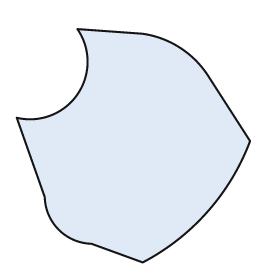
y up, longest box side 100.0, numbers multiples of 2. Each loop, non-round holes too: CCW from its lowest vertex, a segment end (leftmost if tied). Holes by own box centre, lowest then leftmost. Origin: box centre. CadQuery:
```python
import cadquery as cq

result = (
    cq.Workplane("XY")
    .moveTo(4.0, -50.0)
    .threePointArc((32.0, -28.0), (50.0, 2.0))
    .lineTo(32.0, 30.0)
    .threePointArc((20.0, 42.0), (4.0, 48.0))
    .lineTo(-24.0, 50.0)
    .threePointArc((-24.0, 22.0), (-50.0, 12.0))
    .lineTo(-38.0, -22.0)
    .threePointArc((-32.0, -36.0), (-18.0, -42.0))
    .close()
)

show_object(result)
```